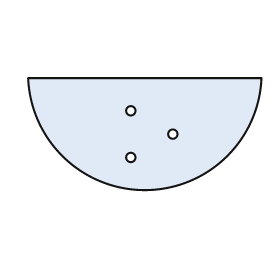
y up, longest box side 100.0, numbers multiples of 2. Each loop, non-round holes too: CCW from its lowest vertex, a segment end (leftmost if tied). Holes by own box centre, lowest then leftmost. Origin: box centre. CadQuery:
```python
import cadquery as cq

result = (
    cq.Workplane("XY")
    .moveTo(-50.0, 24.0)
    .threePointArc((0.0, -24.0), (50.0, 24.0))
    .close()
    .moveTo(-6.0, -10.0)
    .circle(2.0)
    .moveTo(12.0, 0.0)
    .circle(2.0)
    .moveTo(-6.0, 10.0)
    .circle(2.0)
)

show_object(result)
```